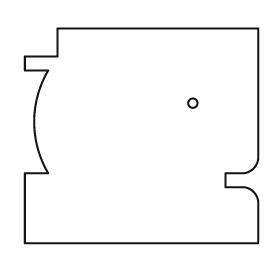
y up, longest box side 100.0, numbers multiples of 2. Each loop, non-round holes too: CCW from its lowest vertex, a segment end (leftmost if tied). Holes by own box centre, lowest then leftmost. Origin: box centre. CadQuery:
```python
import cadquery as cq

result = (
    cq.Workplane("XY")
    .moveTo(-50.0, -46.0)
    .lineTo(50.0, -46.0)
    .lineTo(50.0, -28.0)
    .threePointArc((48.0, -24.0), (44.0, -22.0))
    .lineTo(36.0, -22.0)
    .lineTo(36.0, -16.0)
    .lineTo(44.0, -16.0)
    .threePointArc((48.0, -14.0), (50.0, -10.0))
    .lineTo(50.0, 46.0)
    .lineTo(-36.0, 46.0)
    .lineTo(-36.0, 34.0)
    .lineTo(-50.0, 34.0)
    .lineTo(-50.0, 28.0)
    .lineTo(-40.0, 28.0)
    .threePointArc((-46.0, 6.0), (-40.0, -16.0))
    .lineTo(-50.0, -16.0)
    .close()
    .moveTo(22.0, 14.0)
    .circle(2.0)
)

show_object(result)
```